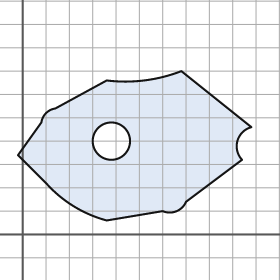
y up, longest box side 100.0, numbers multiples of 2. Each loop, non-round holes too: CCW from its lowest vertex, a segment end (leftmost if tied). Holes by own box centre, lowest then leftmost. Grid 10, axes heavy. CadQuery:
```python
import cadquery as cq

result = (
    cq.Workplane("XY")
    .moveTo(36.0, 6.0)
    .lineTo(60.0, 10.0)
    .threePointArc((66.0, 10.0), (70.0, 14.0))
    .lineTo(94.0, 32.0)
    .threePointArc((92.0, 40.0), (98.0, 46.0))
    .lineTo(68.0, 70.0)
    .threePointArc((52.0, 66.0), (36.0, 66.0))
    .lineTo(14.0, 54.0)
    .threePointArc((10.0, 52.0), (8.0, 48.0))
    .lineTo(-2.0, 34.0)
    .lineTo(10.0, 22.0)
    .threePointArc((22.0, 12.0), (36.0, 6.0))
    .close()
    .moveTo(38.0, 40.0)
    .circle(8.0)
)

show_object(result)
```